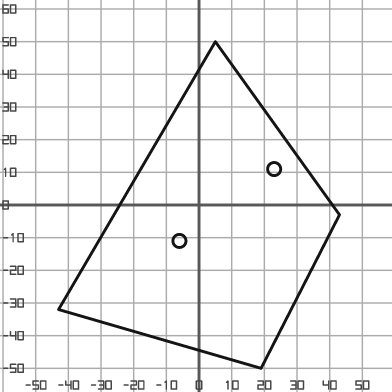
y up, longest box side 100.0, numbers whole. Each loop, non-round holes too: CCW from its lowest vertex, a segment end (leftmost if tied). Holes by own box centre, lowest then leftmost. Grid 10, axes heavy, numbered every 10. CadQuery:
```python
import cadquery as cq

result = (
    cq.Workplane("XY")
    .moveTo(19.0, -50.0)
    .lineTo(43.0, -3.0)
    .lineTo(5.0, 50.0)
    .lineTo(-43.0, -32.0)
    .close()
    .moveTo(-6.0, -11.0)
    .circle(2.0)
    .moveTo(23.0, 11.0)
    .circle(2.0)
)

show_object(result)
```